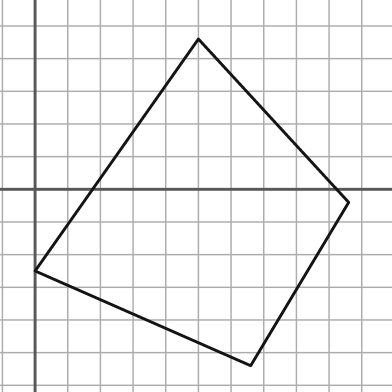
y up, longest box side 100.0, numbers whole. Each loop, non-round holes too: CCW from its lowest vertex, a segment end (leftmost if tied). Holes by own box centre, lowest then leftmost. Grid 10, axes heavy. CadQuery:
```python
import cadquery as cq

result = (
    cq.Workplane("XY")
    .moveTo(66.0, -54.0)
    .lineTo(96.0, -4.0)
    .lineTo(50.0, 46.0)
    .lineTo(0.0, -25.0)
    .close()
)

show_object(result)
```